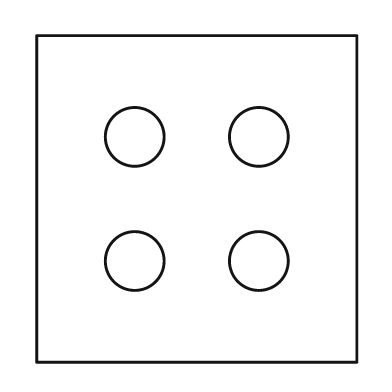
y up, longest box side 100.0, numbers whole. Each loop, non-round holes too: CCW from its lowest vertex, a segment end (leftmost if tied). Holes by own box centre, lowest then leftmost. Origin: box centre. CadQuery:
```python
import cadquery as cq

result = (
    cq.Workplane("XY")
    .moveTo(-49.0, -50.0)
    .lineTo(49.0, -50.0)
    .lineTo(49.0, 50.0)
    .lineTo(-49.0, 50.0)
    .close()
    .moveTo(-19.0, -19.0)
    .circle(9.0)
    .moveTo(19.0, -19.0)
    .circle(9.0)
    .moveTo(-19.0, 19.0)
    .circle(9.0)
    .moveTo(19.0, 19.0)
    .circle(9.0)
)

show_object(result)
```